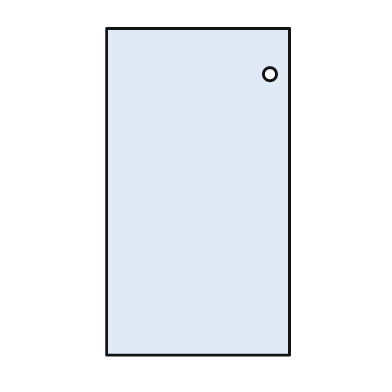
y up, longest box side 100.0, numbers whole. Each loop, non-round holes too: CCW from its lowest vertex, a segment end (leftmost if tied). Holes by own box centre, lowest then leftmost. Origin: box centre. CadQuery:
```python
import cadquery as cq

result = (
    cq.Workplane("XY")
    .moveTo(-28.0, -50.0)
    .lineTo(28.0, -50.0)
    .lineTo(28.0, 50.0)
    .lineTo(-28.0, 50.0)
    .close()
    .moveTo(22.0, 36.0)
    .circle(2.0)
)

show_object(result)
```